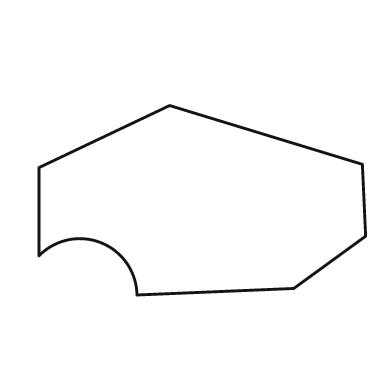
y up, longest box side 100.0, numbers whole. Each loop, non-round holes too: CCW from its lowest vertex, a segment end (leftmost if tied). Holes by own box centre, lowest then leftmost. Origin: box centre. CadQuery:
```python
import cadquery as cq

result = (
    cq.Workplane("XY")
    .moveTo(-20.0, -29.0)
    .lineTo(28.0, -27.0)
    .lineTo(50.0, -11.0)
    .lineTo(49.0, 11.0)
    .lineTo(-10.0, 29.0)
    .lineTo(-50.0, 10.0)
    .lineTo(-50.0, -17.0)
    .threePointArc((-31.0, -13.0), (-20.0, -29.0))
    .close()
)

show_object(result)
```